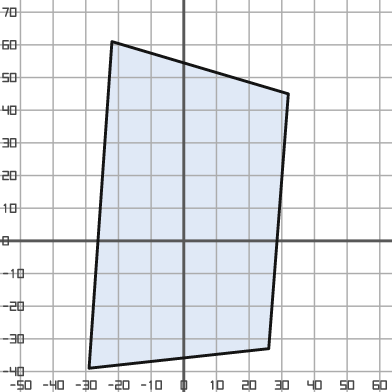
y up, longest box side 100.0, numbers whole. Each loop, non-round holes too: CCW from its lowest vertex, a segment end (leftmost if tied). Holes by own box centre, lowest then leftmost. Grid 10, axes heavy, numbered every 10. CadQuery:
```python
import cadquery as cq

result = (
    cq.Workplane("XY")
    .moveTo(-29.0, -39.0)
    .lineTo(26.0, -33.0)
    .lineTo(32.0, 45.0)
    .lineTo(-22.0, 61.0)
    .close()
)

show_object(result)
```